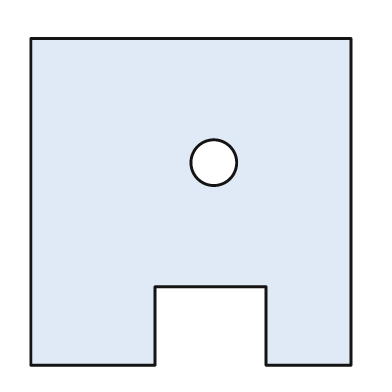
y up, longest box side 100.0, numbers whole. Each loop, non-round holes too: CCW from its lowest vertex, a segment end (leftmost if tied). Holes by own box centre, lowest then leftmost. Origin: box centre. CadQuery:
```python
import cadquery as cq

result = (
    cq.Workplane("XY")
    .moveTo(-49.0, -50.0)
    .lineTo(-11.0, -50.0)
    .lineTo(-11.0, -26.0)
    .lineTo(23.0, -26.0)
    .lineTo(23.0, -50.0)
    .lineTo(49.0, -50.0)
    .lineTo(49.0, 50.0)
    .lineTo(-49.0, 50.0)
    .close()
    .moveTo(7.0, 12.0)
    .circle(7.0)
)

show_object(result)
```